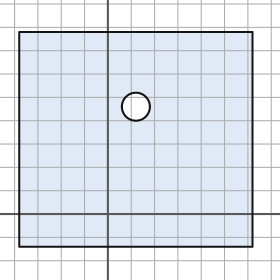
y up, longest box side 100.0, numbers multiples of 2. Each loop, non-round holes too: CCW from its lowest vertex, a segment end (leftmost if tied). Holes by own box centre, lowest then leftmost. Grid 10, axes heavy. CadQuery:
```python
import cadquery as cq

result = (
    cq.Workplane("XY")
    .moveTo(-38.0, -14.0)
    .lineTo(62.0, -14.0)
    .lineTo(62.0, 78.0)
    .lineTo(-38.0, 78.0)
    .close()
    .moveTo(12.0, 46.0)
    .circle(6.0)
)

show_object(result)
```